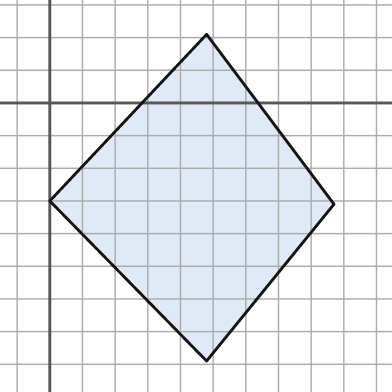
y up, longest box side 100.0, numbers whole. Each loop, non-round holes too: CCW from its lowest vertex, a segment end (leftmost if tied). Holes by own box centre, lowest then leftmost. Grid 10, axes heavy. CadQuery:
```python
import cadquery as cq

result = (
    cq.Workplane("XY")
    .moveTo(48.0, -79.0)
    .lineTo(87.0, -31.0)
    .lineTo(48.0, 21.0)
    .lineTo(0.0, -30.0)
    .close()
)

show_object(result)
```